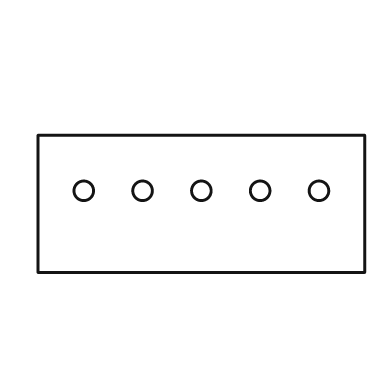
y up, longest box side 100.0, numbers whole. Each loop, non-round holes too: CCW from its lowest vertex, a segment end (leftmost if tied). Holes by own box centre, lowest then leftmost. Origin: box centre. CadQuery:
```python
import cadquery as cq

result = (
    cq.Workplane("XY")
    .moveTo(-50.0, -21.0)
    .lineTo(50.0, -21.0)
    .lineTo(50.0, 21.0)
    .lineTo(-50.0, 21.0)
    .close()
    .moveTo(-36.0, 4.0)
    .circle(3.0)
    .moveTo(-18.0, 4.0)
    .circle(3.0)
    .moveTo(0.0, 4.0)
    .circle(3.0)
    .moveTo(18.0, 4.0)
    .circle(3.0)
    .moveTo(36.0, 4.0)
    .circle(3.0)
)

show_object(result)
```